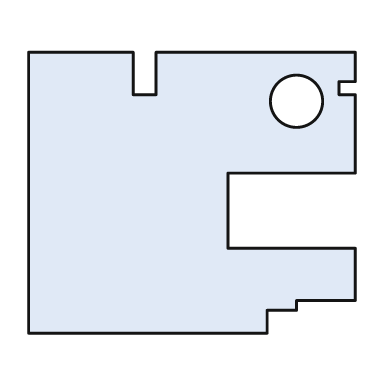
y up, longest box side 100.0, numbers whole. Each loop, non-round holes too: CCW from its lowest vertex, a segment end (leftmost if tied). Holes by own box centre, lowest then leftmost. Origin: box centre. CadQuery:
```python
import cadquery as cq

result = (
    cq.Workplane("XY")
    .moveTo(-50.0, -43.0)
    .lineTo(23.0, -43.0)
    .lineTo(23.0, -36.0)
    .lineTo(32.0, -36.0)
    .lineTo(32.0, -33.0)
    .lineTo(50.0, -33.0)
    .lineTo(50.0, -17.0)
    .lineTo(11.0, -17.0)
    .lineTo(11.0, 6.0)
    .lineTo(50.0, 6.0)
    .lineTo(50.0, 30.0)
    .lineTo(45.0, 30.0)
    .lineTo(45.0, 34.0)
    .lineTo(50.0, 34.0)
    .lineTo(50.0, 43.0)
    .lineTo(-11.0, 43.0)
    .lineTo(-11.0, 30.0)
    .lineTo(-18.0, 30.0)
    .lineTo(-18.0, 43.0)
    .lineTo(-50.0, 43.0)
    .close()
    .moveTo(32.0, 28.0)
    .circle(8.0)
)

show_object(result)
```